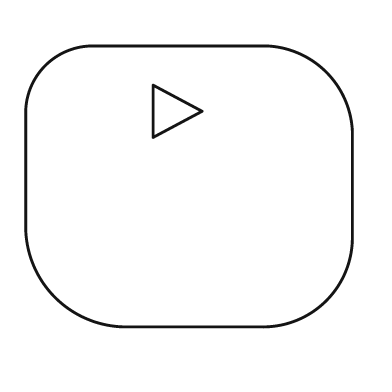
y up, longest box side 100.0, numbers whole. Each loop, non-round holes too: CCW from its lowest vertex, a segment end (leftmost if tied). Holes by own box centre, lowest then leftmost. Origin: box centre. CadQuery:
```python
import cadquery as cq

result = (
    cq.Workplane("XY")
    .moveTo(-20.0, -43.0)
    .lineTo(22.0, -43.0)
    .threePointArc((42.0, -35.0), (50.0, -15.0))
    .lineTo(50.0, 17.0)
    .threePointArc((42.0, 35.0), (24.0, 43.0))
    .lineTo(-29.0, 43.0)
    .threePointArc((-44.0, 37.0), (-50.0, 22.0))
    .lineTo(-50.0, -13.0)
    .threePointArc((-41.0, -34.0), (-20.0, -43.0))
    .close()
    .moveTo(-11.0, 15.0)
    .lineTo(4.0, 23.0)
    .lineTo(-11.0, 31.0)
    .close()
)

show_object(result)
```